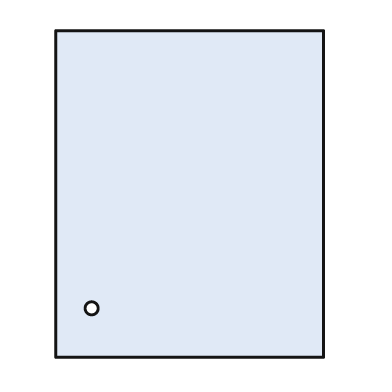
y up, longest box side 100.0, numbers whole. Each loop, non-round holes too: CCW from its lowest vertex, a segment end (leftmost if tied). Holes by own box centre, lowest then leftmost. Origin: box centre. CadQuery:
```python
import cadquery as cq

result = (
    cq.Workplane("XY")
    .moveTo(-41.0, -50.0)
    .lineTo(41.0, -50.0)
    .lineTo(41.0, 50.0)
    .lineTo(-41.0, 50.0)
    .close()
    .moveTo(-30.0, -35.0)
    .circle(2.0)
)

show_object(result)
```